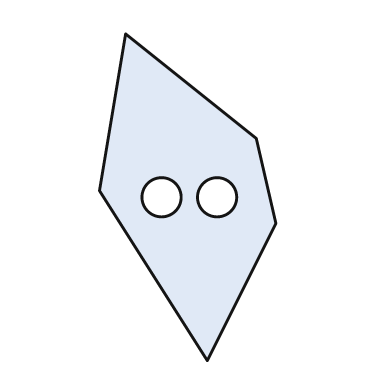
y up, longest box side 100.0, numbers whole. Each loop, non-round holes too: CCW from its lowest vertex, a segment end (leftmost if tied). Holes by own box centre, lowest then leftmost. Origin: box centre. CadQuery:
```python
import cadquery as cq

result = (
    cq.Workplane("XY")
    .moveTo(6.0, -50.0)
    .lineTo(27.0, -8.0)
    .lineTo(21.0, 18.0)
    .lineTo(-19.0, 50.0)
    .lineTo(-27.0, 2.0)
    .close()
    .moveTo(-8.0, 0.0)
    .circle(6.0)
    .moveTo(9.0, 0.0)
    .circle(6.0)
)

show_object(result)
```